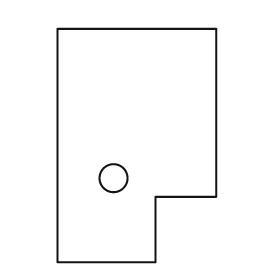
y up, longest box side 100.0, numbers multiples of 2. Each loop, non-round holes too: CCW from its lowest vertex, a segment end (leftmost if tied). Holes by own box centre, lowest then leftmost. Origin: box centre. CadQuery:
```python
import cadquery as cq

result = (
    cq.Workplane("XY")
    .moveTo(-34.0, -50.0)
    .lineTo(8.0, -50.0)
    .lineTo(8.0, -22.0)
    .lineTo(34.0, -22.0)
    .lineTo(34.0, 50.0)
    .lineTo(-34.0, 50.0)
    .close()
    .moveTo(-10.0, -14.0)
    .circle(6.0)
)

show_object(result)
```